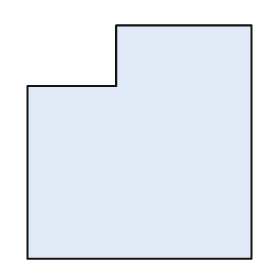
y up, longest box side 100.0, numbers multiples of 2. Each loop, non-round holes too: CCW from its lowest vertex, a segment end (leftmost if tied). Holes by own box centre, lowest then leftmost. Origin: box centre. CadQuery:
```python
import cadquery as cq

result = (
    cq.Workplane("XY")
    .moveTo(-48.0, -50.0)
    .lineTo(48.0, -50.0)
    .lineTo(48.0, 50.0)
    .lineTo(-10.0, 50.0)
    .lineTo(-10.0, 24.0)
    .lineTo(-48.0, 24.0)
    .close()
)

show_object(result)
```